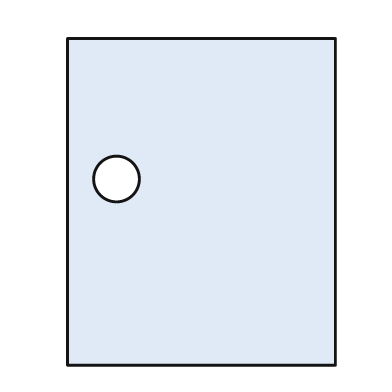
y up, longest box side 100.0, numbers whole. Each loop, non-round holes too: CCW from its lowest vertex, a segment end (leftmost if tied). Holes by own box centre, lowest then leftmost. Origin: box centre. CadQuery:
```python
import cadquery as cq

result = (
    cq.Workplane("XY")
    .moveTo(-41.0, -50.0)
    .lineTo(41.0, -50.0)
    .lineTo(41.0, 50.0)
    .lineTo(-41.0, 50.0)
    .close()
    .moveTo(-26.0, 7.0)
    .circle(7.0)
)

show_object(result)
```